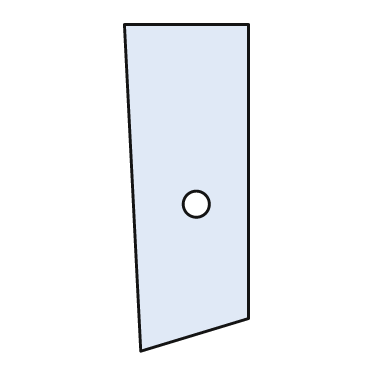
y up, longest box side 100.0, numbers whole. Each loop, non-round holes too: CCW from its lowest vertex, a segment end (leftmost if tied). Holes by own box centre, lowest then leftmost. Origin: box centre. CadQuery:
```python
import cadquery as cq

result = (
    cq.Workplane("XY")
    .moveTo(-14.0, -50.0)
    .lineTo(19.0, -40.0)
    .lineTo(19.0, 50.0)
    .lineTo(-19.0, 50.0)
    .close()
    .moveTo(3.0, -5.0)
    .circle(4.0)
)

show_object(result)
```